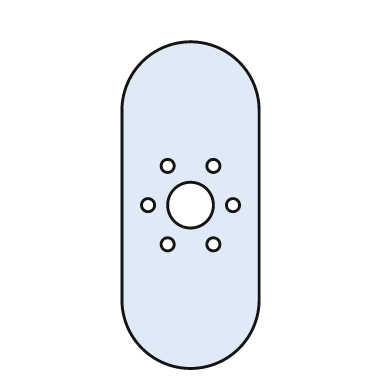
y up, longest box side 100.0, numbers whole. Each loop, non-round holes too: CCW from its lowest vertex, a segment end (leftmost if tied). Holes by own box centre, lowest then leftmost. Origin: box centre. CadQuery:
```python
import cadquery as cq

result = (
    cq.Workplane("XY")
    .moveTo(-21.0, -29.0)
    .threePointArc((0.0, -50.0), (21.0, -29.0))
    .lineTo(21.0, 29.0)
    .threePointArc((0.0, 50.0), (-21.0, 29.0))
    .close()
    .moveTo(-7.0, -12.0)
    .circle(2.0)
    .moveTo(7.0, -12.0)
    .circle(2.0)
    .moveTo(-13.0, 0.0)
    .circle(2.0)
    .moveTo(0.0, 0.0)
    .circle(7.0)
    .moveTo(13.0, 0.0)
    .circle(2.0)
    .moveTo(-7.0, 12.0)
    .circle(2.0)
    .moveTo(7.0, 12.0)
    .circle(2.0)
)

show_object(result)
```